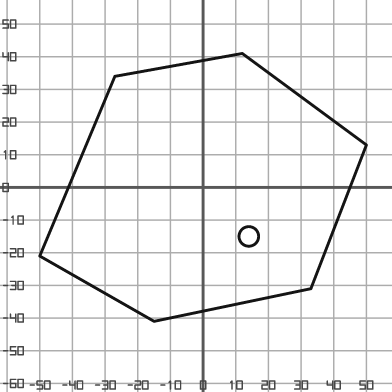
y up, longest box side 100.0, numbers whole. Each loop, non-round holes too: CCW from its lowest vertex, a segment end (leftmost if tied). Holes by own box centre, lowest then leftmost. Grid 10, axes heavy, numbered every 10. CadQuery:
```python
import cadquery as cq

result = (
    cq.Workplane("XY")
    .moveTo(-15.0, -41.0)
    .lineTo(33.0, -31.0)
    .lineTo(50.0, 13.0)
    .lineTo(12.0, 41.0)
    .lineTo(-27.0, 34.0)
    .lineTo(-50.0, -21.0)
    .close()
    .moveTo(14.0, -15.0)
    .circle(3.0)
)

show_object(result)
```